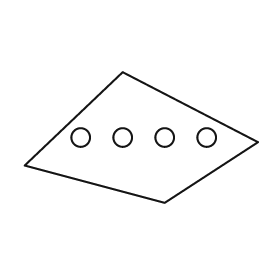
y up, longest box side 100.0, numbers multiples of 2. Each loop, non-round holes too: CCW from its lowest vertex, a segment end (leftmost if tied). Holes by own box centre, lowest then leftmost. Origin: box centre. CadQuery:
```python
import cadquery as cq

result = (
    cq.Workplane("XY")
    .moveTo(10.0, -28.0)
    .lineTo(50.0, -2.0)
    .lineTo(-8.0, 28.0)
    .lineTo(-50.0, -12.0)
    .close()
    .moveTo(-26.0, 0.0)
    .circle(4.0)
    .moveTo(-8.0, 0.0)
    .circle(4.0)
    .moveTo(10.0, 0.0)
    .circle(4.0)
    .moveTo(28.0, 0.0)
    .circle(4.0)
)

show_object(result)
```